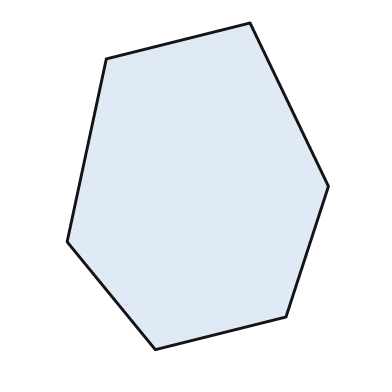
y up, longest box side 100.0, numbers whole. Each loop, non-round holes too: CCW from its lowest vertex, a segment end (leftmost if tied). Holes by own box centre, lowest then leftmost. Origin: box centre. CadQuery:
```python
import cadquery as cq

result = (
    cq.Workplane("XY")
    .moveTo(-13.0, -50.0)
    .lineTo(27.0, -40.0)
    .lineTo(40.0, 0.0)
    .lineTo(16.0, 50.0)
    .lineTo(-28.0, 39.0)
    .lineTo(-40.0, -17.0)
    .close()
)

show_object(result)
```